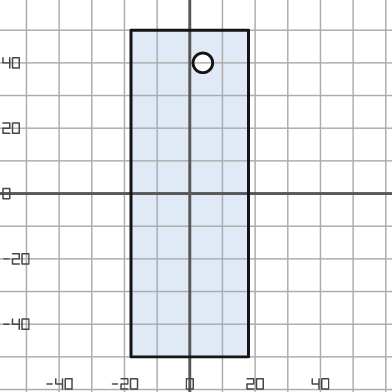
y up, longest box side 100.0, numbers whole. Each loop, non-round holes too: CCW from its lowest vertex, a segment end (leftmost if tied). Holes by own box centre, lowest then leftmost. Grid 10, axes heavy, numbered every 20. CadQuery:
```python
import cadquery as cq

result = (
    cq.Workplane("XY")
    .moveTo(-18.0, -50.0)
    .lineTo(18.0, -50.0)
    .lineTo(18.0, 50.0)
    .lineTo(-18.0, 50.0)
    .close()
    .moveTo(4.0, 40.0)
    .circle(3.0)
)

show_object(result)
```